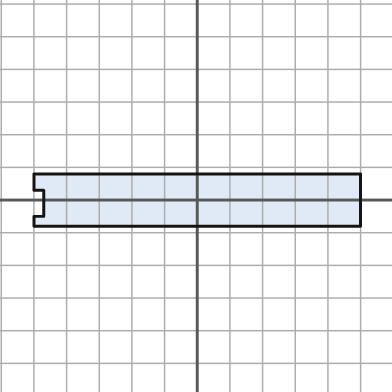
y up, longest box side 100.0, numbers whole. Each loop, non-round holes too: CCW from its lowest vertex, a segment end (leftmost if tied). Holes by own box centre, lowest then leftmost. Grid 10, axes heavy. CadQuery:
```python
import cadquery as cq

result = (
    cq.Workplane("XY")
    .moveTo(-50.0, -8.0)
    .lineTo(50.0, -8.0)
    .lineTo(50.0, 8.0)
    .lineTo(-50.0, 8.0)
    .lineTo(-50.0, 3.0)
    .lineTo(-47.0, 3.0)
    .lineTo(-47.0, -5.0)
    .lineTo(-50.0, -5.0)
    .close()
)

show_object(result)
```